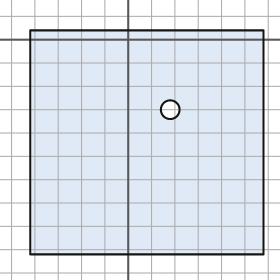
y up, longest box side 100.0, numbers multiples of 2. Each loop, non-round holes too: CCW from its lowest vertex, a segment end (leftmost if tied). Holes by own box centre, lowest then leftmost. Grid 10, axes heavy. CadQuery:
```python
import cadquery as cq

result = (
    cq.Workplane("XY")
    .moveTo(-42.0, -92.0)
    .lineTo(58.0, -92.0)
    .lineTo(58.0, 4.0)
    .lineTo(-42.0, 4.0)
    .close()
    .moveTo(18.0, -30.0)
    .circle(4.0)
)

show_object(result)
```